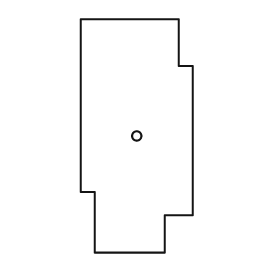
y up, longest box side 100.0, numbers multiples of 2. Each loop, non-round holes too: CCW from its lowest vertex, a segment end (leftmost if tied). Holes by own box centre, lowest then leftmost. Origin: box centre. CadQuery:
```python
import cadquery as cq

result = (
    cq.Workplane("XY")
    .moveTo(-18.0, -50.0)
    .lineTo(12.0, -50.0)
    .lineTo(12.0, -34.0)
    .lineTo(24.0, -34.0)
    .lineTo(24.0, 30.0)
    .lineTo(18.0, 30.0)
    .lineTo(18.0, 50.0)
    .lineTo(-24.0, 50.0)
    .lineTo(-24.0, -24.0)
    .lineTo(-18.0, -24.0)
    .close()
    .moveTo(0.0, 0.0)
    .circle(2.0)
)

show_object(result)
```